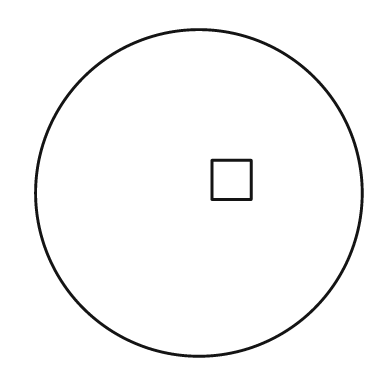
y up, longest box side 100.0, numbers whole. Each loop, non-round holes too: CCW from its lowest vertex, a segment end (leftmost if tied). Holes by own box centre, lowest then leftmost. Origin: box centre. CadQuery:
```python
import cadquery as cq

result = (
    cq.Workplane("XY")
    .moveTo(0.0, 0.0)
    .circle(50.0)
    .moveTo(4.0, -2.0)
    .lineTo(16.0, -2.0)
    .lineTo(16.0, 10.0)
    .lineTo(4.0, 10.0)
    .close()
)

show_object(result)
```